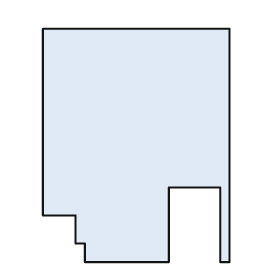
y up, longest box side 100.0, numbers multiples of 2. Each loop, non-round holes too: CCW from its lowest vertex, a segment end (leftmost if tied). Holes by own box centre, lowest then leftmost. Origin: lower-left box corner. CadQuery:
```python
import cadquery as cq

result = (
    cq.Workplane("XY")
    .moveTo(18.0, 0.0)
    .lineTo(54.0, 0.0)
    .lineTo(54.0, 32.0)
    .lineTo(76.0, 32.0)
    .lineTo(76.0, 0.0)
    .lineTo(80.0, 0.0)
    .lineTo(80.0, 100.0)
    .lineTo(0.0, 100.0)
    .lineTo(0.0, 20.0)
    .lineTo(14.0, 20.0)
    .lineTo(14.0, 8.0)
    .lineTo(18.0, 8.0)
    .close()
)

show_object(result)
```